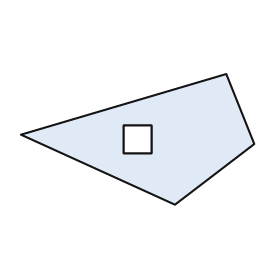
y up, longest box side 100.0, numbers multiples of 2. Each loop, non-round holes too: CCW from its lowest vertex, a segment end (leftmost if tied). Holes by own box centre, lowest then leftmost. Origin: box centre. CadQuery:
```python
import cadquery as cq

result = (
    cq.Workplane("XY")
    .moveTo(16.0, -28.0)
    .lineTo(50.0, -2.0)
    .lineTo(38.0, 28.0)
    .lineTo(-50.0, 2.0)
    .close()
    .moveTo(-6.0, -6.0)
    .lineTo(6.0, -6.0)
    .lineTo(6.0, 6.0)
    .lineTo(-6.0, 6.0)
    .close()
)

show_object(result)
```